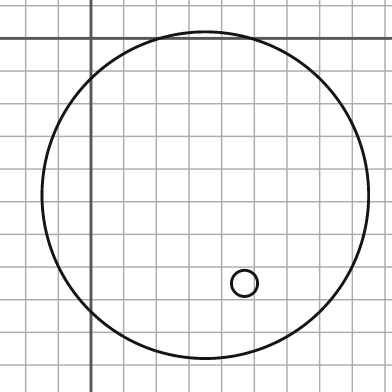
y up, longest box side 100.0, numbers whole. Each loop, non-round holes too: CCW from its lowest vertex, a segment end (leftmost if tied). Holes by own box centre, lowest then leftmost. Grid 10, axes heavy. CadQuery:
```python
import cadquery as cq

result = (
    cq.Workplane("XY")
    .moveTo(35.0, -48.0)
    .circle(50.0)
    .moveTo(47.0, -75.0)
    .circle(4.0)
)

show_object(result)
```